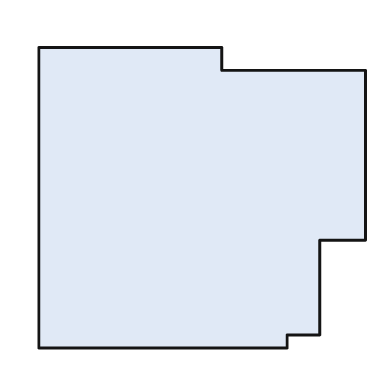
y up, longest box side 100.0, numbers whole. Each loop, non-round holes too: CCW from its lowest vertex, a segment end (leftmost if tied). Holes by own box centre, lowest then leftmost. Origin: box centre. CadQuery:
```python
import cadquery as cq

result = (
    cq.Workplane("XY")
    .moveTo(-50.0, -46.0)
    .lineTo(26.0, -46.0)
    .lineTo(26.0, -42.0)
    .lineTo(36.0, -42.0)
    .lineTo(36.0, -13.0)
    .lineTo(50.0, -13.0)
    .lineTo(50.0, 39.0)
    .lineTo(6.0, 39.0)
    .lineTo(6.0, 46.0)
    .lineTo(-50.0, 46.0)
    .close()
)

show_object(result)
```